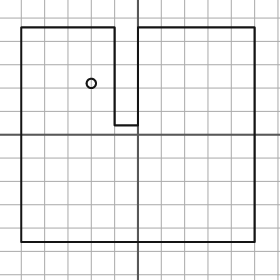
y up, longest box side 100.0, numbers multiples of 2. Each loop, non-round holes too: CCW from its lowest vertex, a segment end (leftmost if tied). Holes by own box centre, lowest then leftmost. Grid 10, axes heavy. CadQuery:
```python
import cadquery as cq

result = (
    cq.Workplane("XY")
    .moveTo(-50.0, -46.0)
    .lineTo(50.0, -46.0)
    .lineTo(50.0, 46.0)
    .lineTo(0.0, 46.0)
    .lineTo(0.0, 4.0)
    .lineTo(-10.0, 4.0)
    .lineTo(-10.0, 46.0)
    .lineTo(-50.0, 46.0)
    .close()
    .moveTo(-20.0, 22.0)
    .circle(2.0)
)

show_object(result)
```